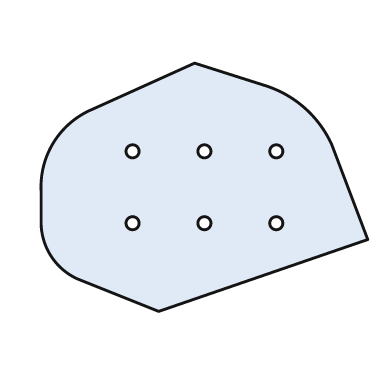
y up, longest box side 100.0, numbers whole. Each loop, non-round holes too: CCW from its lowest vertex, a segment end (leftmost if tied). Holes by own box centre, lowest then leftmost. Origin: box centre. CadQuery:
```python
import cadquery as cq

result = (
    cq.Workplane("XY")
    .moveTo(-14.0, -38.0)
    .lineTo(50.0, -16.0)
    .lineTo(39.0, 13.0)
    .threePointArc((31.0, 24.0), (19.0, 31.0))
    .lineTo(-3.0, 38.0)
    .lineTo(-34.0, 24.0)
    .threePointArc((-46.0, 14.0), (-50.0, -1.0))
    .lineTo(-50.0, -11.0)
    .threePointArc((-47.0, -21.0), (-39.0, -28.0))
    .close()
    .moveTo(-22.0, -11.0)
    .circle(2.0)
    .moveTo(0.0, -11.0)
    .circle(2.0)
    .moveTo(22.0, -11.0)
    .circle(2.0)
    .moveTo(-22.0, 11.0)
    .circle(2.0)
    .moveTo(0.0, 11.0)
    .circle(2.0)
    .moveTo(22.0, 11.0)
    .circle(2.0)
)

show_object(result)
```